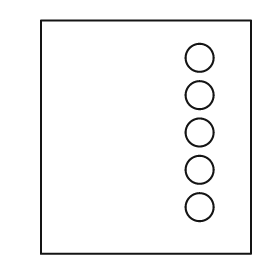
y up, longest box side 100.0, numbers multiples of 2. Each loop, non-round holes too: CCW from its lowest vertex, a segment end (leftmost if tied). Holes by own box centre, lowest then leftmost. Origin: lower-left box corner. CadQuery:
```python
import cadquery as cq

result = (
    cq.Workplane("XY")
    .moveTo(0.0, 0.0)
    .lineTo(90.0, 0.0)
    .lineTo(90.0, 100.0)
    .lineTo(0.0, 100.0)
    .close()
    .moveTo(68.0, 20.0)
    .circle(6.0)
    .moveTo(68.0, 36.0)
    .circle(6.0)
    .moveTo(68.0, 52.0)
    .circle(6.0)
    .moveTo(68.0, 68.0)
    .circle(6.0)
    .moveTo(68.0, 84.0)
    .circle(6.0)
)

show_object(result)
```